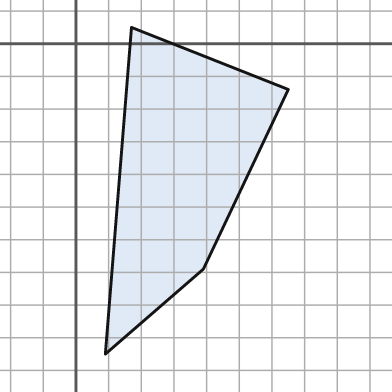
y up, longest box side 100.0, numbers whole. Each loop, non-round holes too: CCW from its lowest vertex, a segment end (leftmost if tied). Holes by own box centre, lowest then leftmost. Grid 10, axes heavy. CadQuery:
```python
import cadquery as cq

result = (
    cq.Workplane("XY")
    .moveTo(9.0, -95.0)
    .lineTo(39.0, -69.0)
    .lineTo(65.0, -14.0)
    .lineTo(17.0, 5.0)
    .close()
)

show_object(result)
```